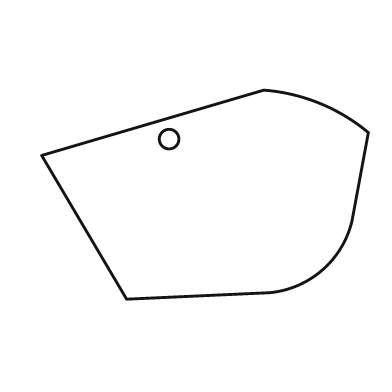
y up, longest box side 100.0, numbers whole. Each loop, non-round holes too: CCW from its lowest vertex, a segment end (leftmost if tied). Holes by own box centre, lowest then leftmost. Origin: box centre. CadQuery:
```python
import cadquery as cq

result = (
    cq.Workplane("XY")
    .moveTo(-24.0, -32.0)
    .lineTo(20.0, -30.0)
    .threePointArc((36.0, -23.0), (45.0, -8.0))
    .lineTo(50.0, 19.0)
    .threePointArc((35.0, 28.0), (18.0, 32.0))
    .lineTo(-50.0, 12.0)
    .close()
    .moveTo(-11.0, 17.0)
    .circle(3.0)
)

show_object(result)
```